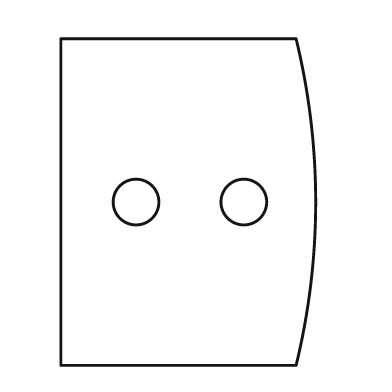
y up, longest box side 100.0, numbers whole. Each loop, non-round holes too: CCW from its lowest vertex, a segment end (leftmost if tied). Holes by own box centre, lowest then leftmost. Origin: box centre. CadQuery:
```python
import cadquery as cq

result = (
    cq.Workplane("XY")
    .moveTo(-39.0, -50.0)
    .lineTo(33.0, -50.0)
    .threePointArc((39.0, 0.0), (33.0, 50.0))
    .lineTo(-39.0, 50.0)
    .close()
    .moveTo(-16.0, 0.0)
    .circle(7.0)
    .moveTo(17.0, 0.0)
    .circle(7.0)
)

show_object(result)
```